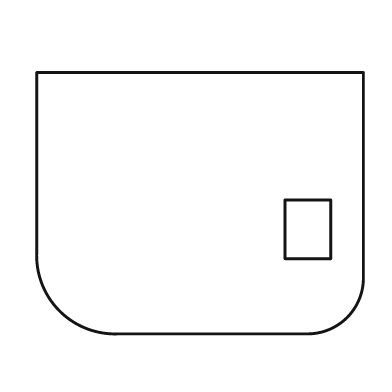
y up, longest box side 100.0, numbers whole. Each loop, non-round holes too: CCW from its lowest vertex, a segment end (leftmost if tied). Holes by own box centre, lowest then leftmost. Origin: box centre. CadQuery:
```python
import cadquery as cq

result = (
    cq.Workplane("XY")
    .moveTo(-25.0, -40.0)
    .lineTo(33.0, -40.0)
    .threePointArc((45.0, -35.0), (50.0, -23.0))
    .lineTo(50.0, 40.0)
    .lineTo(-50.0, 40.0)
    .lineTo(-50.0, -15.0)
    .threePointArc((-43.0, -33.0), (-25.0, -40.0))
    .close()
    .moveTo(26.0, -17.0)
    .lineTo(40.0, -17.0)
    .lineTo(40.0, 1.0)
    .lineTo(26.0, 1.0)
    .close()
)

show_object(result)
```